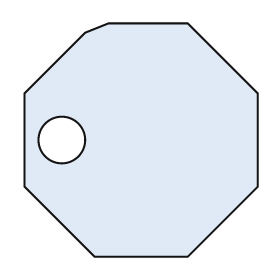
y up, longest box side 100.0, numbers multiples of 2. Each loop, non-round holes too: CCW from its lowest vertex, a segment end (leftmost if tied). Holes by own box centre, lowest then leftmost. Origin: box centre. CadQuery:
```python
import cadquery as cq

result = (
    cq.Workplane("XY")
    .moveTo(-20.0, -50.0)
    .lineTo(20.0, -50.0)
    .lineTo(50.0, -20.0)
    .lineTo(50.0, 20.0)
    .lineTo(20.0, 50.0)
    .lineTo(-14.0, 50.0)
    .lineTo(-24.0, 46.0)
    .lineTo(-50.0, 20.0)
    .lineTo(-50.0, -20.0)
    .close()
    .moveTo(-34.0, 0.0)
    .circle(10.0)
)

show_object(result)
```